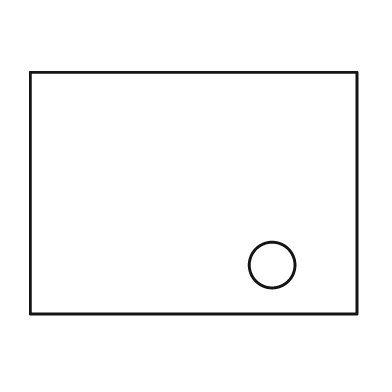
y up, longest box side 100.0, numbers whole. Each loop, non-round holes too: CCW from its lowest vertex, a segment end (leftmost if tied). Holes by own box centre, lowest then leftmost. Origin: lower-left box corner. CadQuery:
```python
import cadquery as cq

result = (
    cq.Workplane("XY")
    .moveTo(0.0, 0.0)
    .lineTo(100.0, 0.0)
    .lineTo(100.0, 74.0)
    .lineTo(0.0, 74.0)
    .close()
    .moveTo(74.0, 15.0)
    .circle(7.0)
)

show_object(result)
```